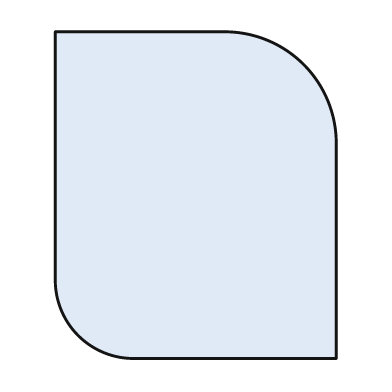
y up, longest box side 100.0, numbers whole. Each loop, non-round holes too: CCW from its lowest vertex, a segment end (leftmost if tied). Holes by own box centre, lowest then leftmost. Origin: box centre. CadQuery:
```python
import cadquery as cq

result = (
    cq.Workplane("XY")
    .moveTo(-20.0, -50.0)
    .lineTo(43.0, -50.0)
    .lineTo(43.0, 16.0)
    .threePointArc((33.0, 40.0), (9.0, 50.0))
    .lineTo(-43.0, 50.0)
    .lineTo(-43.0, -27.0)
    .threePointArc((-36.0, -43.0), (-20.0, -50.0))
    .close()
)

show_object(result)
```